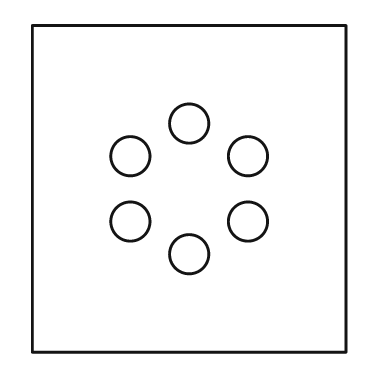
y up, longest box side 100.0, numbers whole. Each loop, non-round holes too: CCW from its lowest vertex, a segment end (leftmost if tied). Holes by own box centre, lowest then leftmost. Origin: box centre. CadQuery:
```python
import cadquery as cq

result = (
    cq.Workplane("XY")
    .moveTo(-48.0, -50.0)
    .lineTo(48.0, -50.0)
    .lineTo(48.0, 50.0)
    .lineTo(-48.0, 50.0)
    .close()
    .moveTo(0.0, -20.0)
    .circle(6.0)
    .moveTo(-18.0, -10.0)
    .circle(6.0)
    .moveTo(18.0, -10.0)
    .circle(6.0)
    .moveTo(-18.0, 10.0)
    .circle(6.0)
    .moveTo(18.0, 10.0)
    .circle(6.0)
    .moveTo(0.0, 20.0)
    .circle(6.0)
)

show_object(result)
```